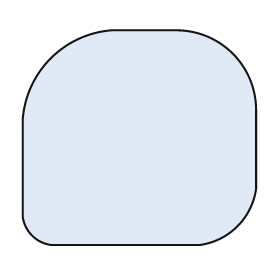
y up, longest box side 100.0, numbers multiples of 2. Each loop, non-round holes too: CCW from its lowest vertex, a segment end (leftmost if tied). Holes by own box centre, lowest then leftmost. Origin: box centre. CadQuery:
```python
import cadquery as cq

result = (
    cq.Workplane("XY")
    .moveTo(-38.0, -46.0)
    .lineTo(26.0, -46.0)
    .threePointArc((42.0, -38.0), (50.0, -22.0))
    .lineTo(50.0, 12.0)
    .threePointArc((40.0, 36.0), (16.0, 46.0))
    .lineTo(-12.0, 46.0)
    .threePointArc((-38.0, 34.0), (-50.0, 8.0))
    .lineTo(-50.0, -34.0)
    .threePointArc((-46.0, -42.0), (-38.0, -46.0))
    .close()
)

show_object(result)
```